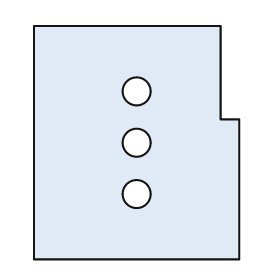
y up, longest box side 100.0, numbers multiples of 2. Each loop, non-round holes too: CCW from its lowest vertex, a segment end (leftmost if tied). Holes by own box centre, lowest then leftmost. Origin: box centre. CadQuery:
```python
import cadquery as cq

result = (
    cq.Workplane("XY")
    .moveTo(-44.0, -50.0)
    .lineTo(44.0, -50.0)
    .lineTo(44.0, 10.0)
    .lineTo(36.0, 10.0)
    .lineTo(36.0, 50.0)
    .lineTo(-44.0, 50.0)
    .close()
    .moveTo(0.0, -22.0)
    .circle(6.0)
    .moveTo(0.0, 0.0)
    .circle(6.0)
    .moveTo(0.0, 22.0)
    .circle(6.0)
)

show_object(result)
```